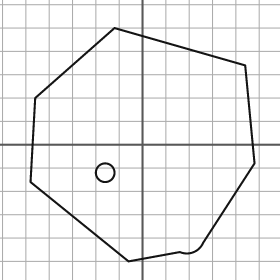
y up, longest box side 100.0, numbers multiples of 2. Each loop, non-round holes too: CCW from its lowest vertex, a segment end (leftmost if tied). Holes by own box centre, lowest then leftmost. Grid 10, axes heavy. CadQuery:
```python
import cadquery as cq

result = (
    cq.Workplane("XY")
    .moveTo(-6.0, -50.0)
    .lineTo(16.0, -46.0)
    .threePointArc((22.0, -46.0), (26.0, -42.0))
    .lineTo(48.0, -8.0)
    .lineTo(44.0, 34.0)
    .lineTo(-12.0, 50.0)
    .lineTo(-46.0, 20.0)
    .lineTo(-48.0, -16.0)
    .close()
    .moveTo(-16.0, -12.0)
    .circle(4.0)
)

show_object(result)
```